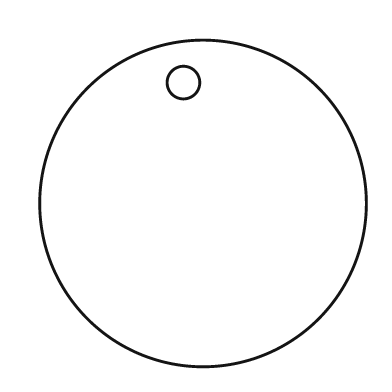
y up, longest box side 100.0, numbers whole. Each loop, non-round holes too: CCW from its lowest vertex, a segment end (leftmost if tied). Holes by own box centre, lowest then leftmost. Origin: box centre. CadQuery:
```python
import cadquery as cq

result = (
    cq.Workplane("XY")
    .moveTo(0.0, 0.0)
    .circle(50.0)
    .moveTo(-6.0, 37.0)
    .circle(5.0)
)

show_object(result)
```